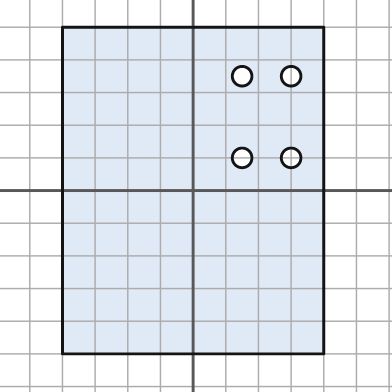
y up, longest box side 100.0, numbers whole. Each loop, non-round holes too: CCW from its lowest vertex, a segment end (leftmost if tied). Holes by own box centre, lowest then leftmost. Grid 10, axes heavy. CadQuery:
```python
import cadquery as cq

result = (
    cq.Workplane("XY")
    .moveTo(-40.0, -50.0)
    .lineTo(40.0, -50.0)
    .lineTo(40.0, 50.0)
    .lineTo(-40.0, 50.0)
    .close()
    .moveTo(15.0, 10.0)
    .circle(3.0)
    .moveTo(30.0, 10.0)
    .circle(3.0)
    .moveTo(15.0, 35.0)
    .circle(3.0)
    .moveTo(30.0, 35.0)
    .circle(3.0)
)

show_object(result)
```